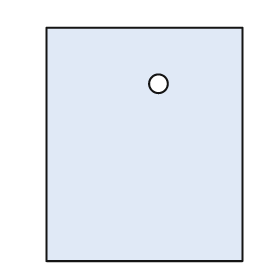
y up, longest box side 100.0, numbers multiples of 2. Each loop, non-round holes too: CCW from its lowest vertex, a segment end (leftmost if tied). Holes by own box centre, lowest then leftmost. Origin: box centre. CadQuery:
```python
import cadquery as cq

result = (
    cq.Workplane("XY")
    .moveTo(-42.0, -50.0)
    .lineTo(42.0, -50.0)
    .lineTo(42.0, 50.0)
    .lineTo(-42.0, 50.0)
    .close()
    .moveTo(6.0, 26.0)
    .circle(4.0)
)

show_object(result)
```